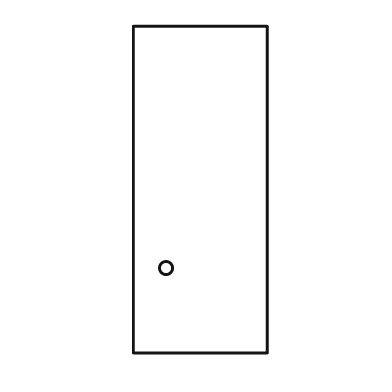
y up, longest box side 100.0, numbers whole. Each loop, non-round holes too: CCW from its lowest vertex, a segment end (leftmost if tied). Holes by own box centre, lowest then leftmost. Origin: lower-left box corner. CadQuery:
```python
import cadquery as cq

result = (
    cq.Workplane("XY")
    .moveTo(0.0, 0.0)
    .lineTo(41.0, 0.0)
    .lineTo(41.0, 100.0)
    .lineTo(0.0, 100.0)
    .close()
    .moveTo(10.0, 26.0)
    .circle(2.0)
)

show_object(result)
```